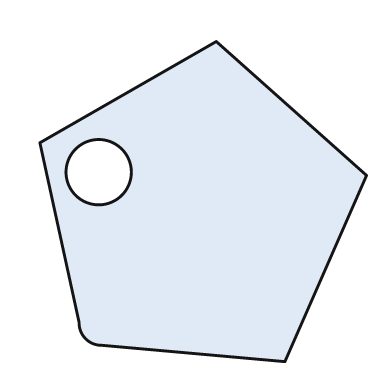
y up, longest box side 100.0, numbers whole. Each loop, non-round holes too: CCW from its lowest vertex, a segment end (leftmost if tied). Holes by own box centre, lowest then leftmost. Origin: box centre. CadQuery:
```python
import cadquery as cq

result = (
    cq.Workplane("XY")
    .moveTo(25.0, -49.0)
    .lineTo(50.0, 8.0)
    .lineTo(4.0, 49.0)
    .lineTo(-50.0, 18.0)
    .lineTo(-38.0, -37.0)
    .threePointArc((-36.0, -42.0), (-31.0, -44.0))
    .close()
    .moveTo(-32.0, 9.0)
    .circle(10.0)
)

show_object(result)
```